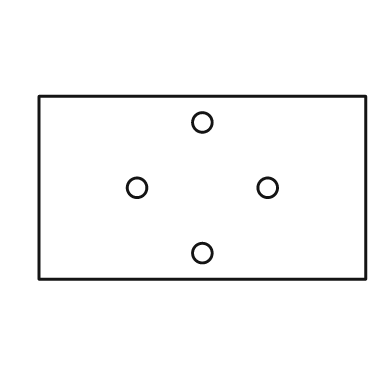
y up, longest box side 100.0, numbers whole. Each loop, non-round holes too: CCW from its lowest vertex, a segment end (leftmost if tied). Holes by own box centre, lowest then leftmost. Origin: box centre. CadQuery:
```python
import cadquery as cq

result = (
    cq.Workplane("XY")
    .moveTo(-50.0, -28.0)
    .lineTo(50.0, -28.0)
    .lineTo(50.0, 28.0)
    .lineTo(-50.0, 28.0)
    .close()
    .moveTo(0.0, -20.0)
    .circle(3.0)
    .moveTo(-20.0, 0.0)
    .circle(3.0)
    .moveTo(20.0, 0.0)
    .circle(3.0)
    .moveTo(0.0, 20.0)
    .circle(3.0)
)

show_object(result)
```